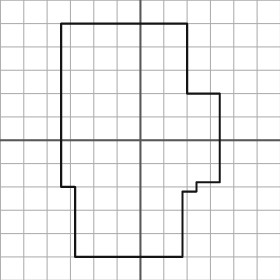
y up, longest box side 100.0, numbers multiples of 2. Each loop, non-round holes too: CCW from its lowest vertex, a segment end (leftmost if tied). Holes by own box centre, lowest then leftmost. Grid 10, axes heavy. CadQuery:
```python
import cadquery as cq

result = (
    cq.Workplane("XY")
    .moveTo(-28.0, -50.0)
    .lineTo(18.0, -50.0)
    .lineTo(18.0, -22.0)
    .lineTo(24.0, -22.0)
    .lineTo(24.0, -18.0)
    .lineTo(34.0, -18.0)
    .lineTo(34.0, 20.0)
    .lineTo(20.0, 20.0)
    .lineTo(20.0, 50.0)
    .lineTo(-34.0, 50.0)
    .lineTo(-34.0, -20.0)
    .lineTo(-28.0, -20.0)
    .close()
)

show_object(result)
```